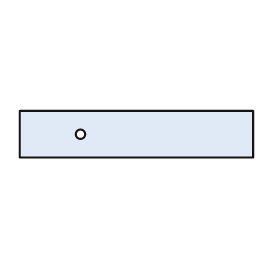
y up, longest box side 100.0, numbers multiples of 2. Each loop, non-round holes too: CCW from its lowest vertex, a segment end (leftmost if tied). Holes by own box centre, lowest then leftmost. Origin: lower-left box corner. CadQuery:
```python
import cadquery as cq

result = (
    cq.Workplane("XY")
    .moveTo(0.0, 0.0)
    .lineTo(100.0, 0.0)
    .lineTo(100.0, 20.0)
    .lineTo(0.0, 20.0)
    .close()
    .moveTo(26.0, 10.0)
    .circle(2.0)
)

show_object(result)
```